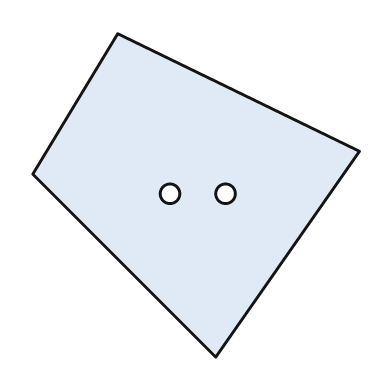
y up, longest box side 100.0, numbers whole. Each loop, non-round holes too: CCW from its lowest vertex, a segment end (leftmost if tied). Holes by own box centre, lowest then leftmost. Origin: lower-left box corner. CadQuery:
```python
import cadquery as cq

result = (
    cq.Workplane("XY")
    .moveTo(56.0, 0.0)
    .lineTo(100.0, 63.0)
    .lineTo(26.0, 99.0)
    .lineTo(0.0, 56.0)
    .close()
    .moveTo(42.0, 50.0)
    .circle(3.0)
    .moveTo(59.0, 50.0)
    .circle(3.0)
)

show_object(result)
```